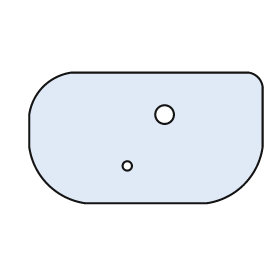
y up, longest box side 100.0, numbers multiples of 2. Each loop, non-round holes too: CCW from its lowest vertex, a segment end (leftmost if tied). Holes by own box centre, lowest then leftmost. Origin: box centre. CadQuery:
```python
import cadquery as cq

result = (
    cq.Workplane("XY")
    .moveTo(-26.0, -28.0)
    .lineTo(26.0, -28.0)
    .threePointArc((42.0, -20.0), (50.0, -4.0))
    .lineTo(50.0, 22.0)
    .threePointArc((48.0, 26.0), (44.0, 28.0))
    .lineTo(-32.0, 28.0)
    .threePointArc((-44.0, 22.0), (-50.0, 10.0))
    .lineTo(-50.0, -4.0)
    .threePointArc((-42.0, -20.0), (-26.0, -28.0))
    .close()
    .moveTo(-8.0, -12.0)
    .circle(2.0)
    .moveTo(8.0, 10.0)
    .circle(4.0)
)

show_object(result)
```